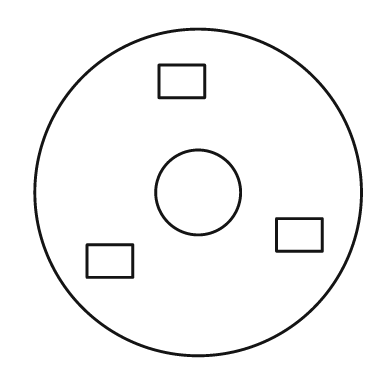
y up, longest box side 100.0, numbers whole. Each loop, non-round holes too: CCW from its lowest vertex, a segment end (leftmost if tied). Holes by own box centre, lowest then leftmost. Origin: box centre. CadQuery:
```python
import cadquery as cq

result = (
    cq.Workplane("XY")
    .moveTo(0.0, 0.0)
    .circle(50.0)
    .moveTo(-34.0, -26.0)
    .lineTo(-20.0, -26.0)
    .lineTo(-20.0, -16.0)
    .lineTo(-34.0, -16.0)
    .close()
    .moveTo(24.0, -18.0)
    .lineTo(38.0, -18.0)
    .lineTo(38.0, -8.0)
    .lineTo(24.0, -8.0)
    .close()
    .moveTo(0.0, 0.0)
    .circle(13.0)
    .moveTo(-12.0, 29.0)
    .lineTo(2.0, 29.0)
    .lineTo(2.0, 39.0)
    .lineTo(-12.0, 39.0)
    .close()
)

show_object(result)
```